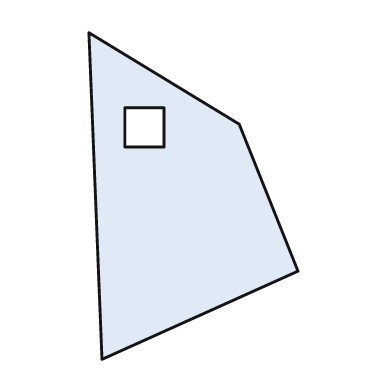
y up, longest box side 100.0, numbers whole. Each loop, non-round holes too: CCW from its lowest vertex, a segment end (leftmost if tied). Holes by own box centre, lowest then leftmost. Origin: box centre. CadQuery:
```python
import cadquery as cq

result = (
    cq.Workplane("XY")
    .moveTo(-28.0, -50.0)
    .lineTo(32.0, -23.0)
    .lineTo(14.0, 22.0)
    .lineTo(-32.0, 50.0)
    .close()
    .moveTo(-21.0, 15.0)
    .lineTo(-9.0, 15.0)
    .lineTo(-9.0, 27.0)
    .lineTo(-21.0, 27.0)
    .close()
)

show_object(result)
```